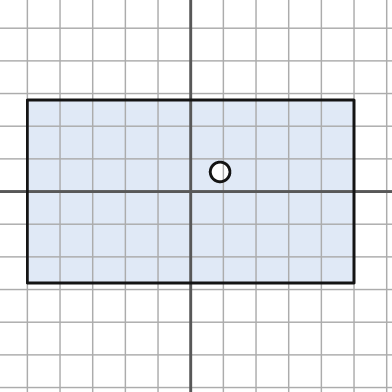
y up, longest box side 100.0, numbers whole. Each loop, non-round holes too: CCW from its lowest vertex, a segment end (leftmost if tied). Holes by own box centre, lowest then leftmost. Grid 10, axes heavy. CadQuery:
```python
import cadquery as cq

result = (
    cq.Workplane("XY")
    .moveTo(-50.0, -28.0)
    .lineTo(50.0, -28.0)
    .lineTo(50.0, 28.0)
    .lineTo(-50.0, 28.0)
    .close()
    .moveTo(9.0, 6.0)
    .circle(3.0)
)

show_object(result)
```